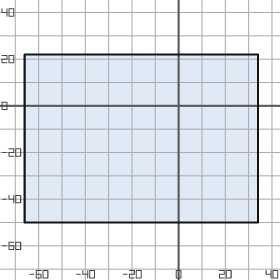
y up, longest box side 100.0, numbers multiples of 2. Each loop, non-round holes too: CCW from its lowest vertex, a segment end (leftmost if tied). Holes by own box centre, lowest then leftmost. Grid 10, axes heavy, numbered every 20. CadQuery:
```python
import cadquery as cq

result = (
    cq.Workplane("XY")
    .moveTo(-66.0, -50.0)
    .lineTo(34.0, -50.0)
    .lineTo(34.0, 22.0)
    .lineTo(-66.0, 22.0)
    .close()
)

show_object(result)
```